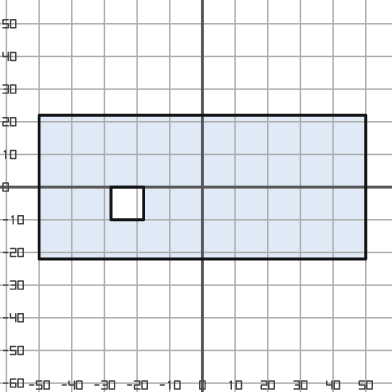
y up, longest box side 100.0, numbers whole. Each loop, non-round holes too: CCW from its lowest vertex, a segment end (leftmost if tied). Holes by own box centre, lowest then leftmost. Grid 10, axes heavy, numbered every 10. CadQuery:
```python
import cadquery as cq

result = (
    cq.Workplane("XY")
    .moveTo(-50.0, -22.0)
    .lineTo(50.0, -22.0)
    .lineTo(50.0, 22.0)
    .lineTo(-50.0, 22.0)
    .close()
    .moveTo(-28.0, -10.0)
    .lineTo(-18.0, -10.0)
    .lineTo(-18.0, 0.0)
    .lineTo(-28.0, 0.0)
    .close()
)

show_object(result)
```